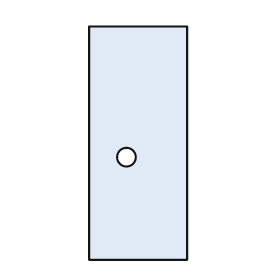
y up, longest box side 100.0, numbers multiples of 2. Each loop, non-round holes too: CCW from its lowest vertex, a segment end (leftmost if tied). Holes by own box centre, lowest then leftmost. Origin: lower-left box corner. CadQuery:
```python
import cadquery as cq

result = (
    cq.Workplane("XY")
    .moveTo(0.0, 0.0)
    .lineTo(42.0, 0.0)
    .lineTo(42.0, 100.0)
    .lineTo(0.0, 100.0)
    .close()
    .moveTo(16.0, 44.0)
    .circle(4.0)
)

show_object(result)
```